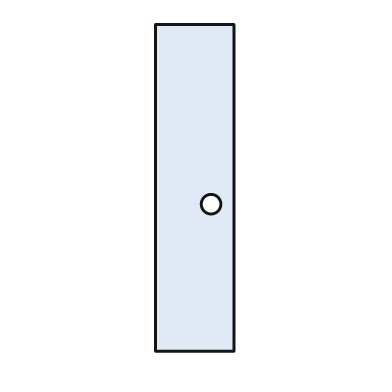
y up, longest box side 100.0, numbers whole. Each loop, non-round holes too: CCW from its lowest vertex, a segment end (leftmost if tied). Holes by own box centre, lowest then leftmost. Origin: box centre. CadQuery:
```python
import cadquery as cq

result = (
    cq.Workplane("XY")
    .moveTo(-12.0, -50.0)
    .lineTo(12.0, -50.0)
    .lineTo(12.0, 50.0)
    .lineTo(-12.0, 50.0)
    .close()
    .moveTo(5.0, -5.0)
    .circle(3.0)
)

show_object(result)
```